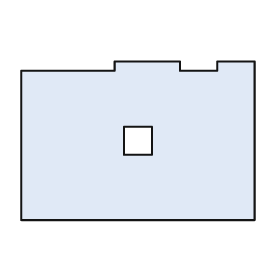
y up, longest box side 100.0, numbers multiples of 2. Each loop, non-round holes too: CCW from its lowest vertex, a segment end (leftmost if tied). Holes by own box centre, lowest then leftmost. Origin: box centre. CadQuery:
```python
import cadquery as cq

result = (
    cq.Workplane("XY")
    .moveTo(-50.0, -34.0)
    .lineTo(50.0, -34.0)
    .lineTo(50.0, 34.0)
    .lineTo(34.0, 34.0)
    .lineTo(34.0, 30.0)
    .lineTo(18.0, 30.0)
    .lineTo(18.0, 34.0)
    .lineTo(-10.0, 34.0)
    .lineTo(-10.0, 30.0)
    .lineTo(-50.0, 30.0)
    .close()
    .moveTo(-6.0, -6.0)
    .lineTo(6.0, -6.0)
    .lineTo(6.0, 6.0)
    .lineTo(-6.0, 6.0)
    .close()
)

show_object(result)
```